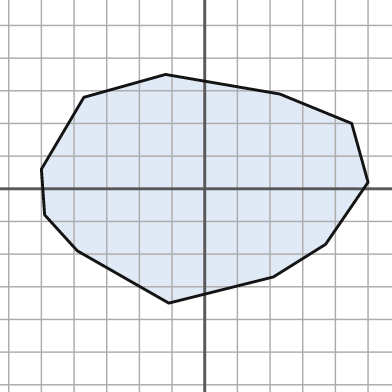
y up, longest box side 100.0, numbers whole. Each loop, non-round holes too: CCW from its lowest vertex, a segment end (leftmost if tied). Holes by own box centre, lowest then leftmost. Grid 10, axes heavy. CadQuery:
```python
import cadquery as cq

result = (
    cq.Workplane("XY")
    .moveTo(-11.0, -35.0)
    .lineTo(21.0, -27.0)
    .lineTo(37.0, -17.0)
    .lineTo(50.0, 2.0)
    .lineTo(45.0, 20.0)
    .lineTo(23.0, 29.0)
    .lineTo(-12.0, 35.0)
    .lineTo(-37.0, 28.0)
    .lineTo(-50.0, 6.0)
    .lineTo(-49.0, -8.0)
    .lineTo(-39.0, -19.0)
    .close()
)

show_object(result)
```